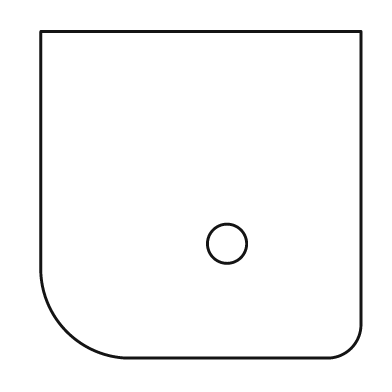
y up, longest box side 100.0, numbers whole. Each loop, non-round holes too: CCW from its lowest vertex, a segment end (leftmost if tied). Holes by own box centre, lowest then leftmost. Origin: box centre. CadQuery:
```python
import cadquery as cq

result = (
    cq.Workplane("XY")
    .moveTo(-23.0, -50.0)
    .lineTo(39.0, -50.0)
    .threePointArc((46.0, -47.0), (49.0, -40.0))
    .lineTo(49.0, 50.0)
    .lineTo(-49.0, 50.0)
    .lineTo(-49.0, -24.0)
    .threePointArc((-41.0, -42.0), (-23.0, -50.0))
    .close()
    .moveTo(8.0, -15.0)
    .circle(6.0)
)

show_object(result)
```